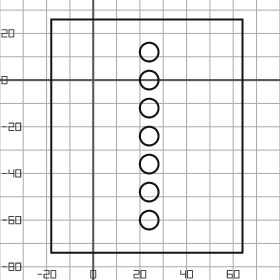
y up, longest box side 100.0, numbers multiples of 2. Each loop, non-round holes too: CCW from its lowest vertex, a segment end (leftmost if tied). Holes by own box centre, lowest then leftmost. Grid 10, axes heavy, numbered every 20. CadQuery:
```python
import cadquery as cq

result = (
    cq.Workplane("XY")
    .moveTo(-18.0, -74.0)
    .lineTo(64.0, -74.0)
    .lineTo(64.0, 26.0)
    .lineTo(-18.0, 26.0)
    .close()
    .moveTo(24.0, -60.0)
    .circle(4.0)
    .moveTo(24.0, -48.0)
    .circle(4.0)
    .moveTo(24.0, -36.0)
    .circle(4.0)
    .moveTo(24.0, -24.0)
    .circle(4.0)
    .moveTo(24.0, -12.0)
    .circle(4.0)
    .moveTo(24.0, 0.0)
    .circle(4.0)
    .moveTo(24.0, 12.0)
    .circle(4.0)
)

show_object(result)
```